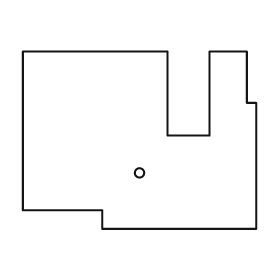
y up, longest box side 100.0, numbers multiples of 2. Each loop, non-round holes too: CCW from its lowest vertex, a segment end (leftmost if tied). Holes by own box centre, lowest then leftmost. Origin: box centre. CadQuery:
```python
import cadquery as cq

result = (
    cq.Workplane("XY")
    .moveTo(-16.0, -38.0)
    .lineTo(50.0, -38.0)
    .lineTo(50.0, 16.0)
    .lineTo(46.0, 16.0)
    .lineTo(46.0, 38.0)
    .lineTo(30.0, 38.0)
    .lineTo(30.0, 2.0)
    .lineTo(12.0, 2.0)
    .lineTo(12.0, 38.0)
    .lineTo(-50.0, 38.0)
    .lineTo(-50.0, -30.0)
    .lineTo(-16.0, -30.0)
    .close()
    .moveTo(0.0, -14.0)
    .circle(2.0)
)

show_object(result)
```